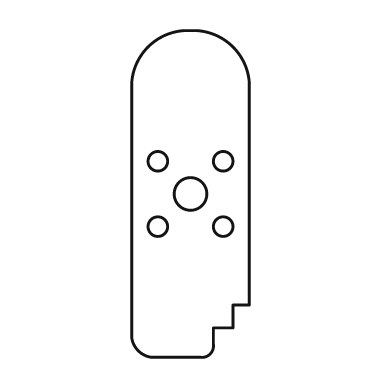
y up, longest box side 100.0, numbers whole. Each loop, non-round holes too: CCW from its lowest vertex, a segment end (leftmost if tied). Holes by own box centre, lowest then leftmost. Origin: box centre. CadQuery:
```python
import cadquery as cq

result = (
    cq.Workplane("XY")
    .moveTo(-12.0, -50.0)
    .lineTo(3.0, -50.0)
    .threePointArc((6.0, -49.0), (7.0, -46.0))
    .lineTo(7.0, -41.0)
    .lineTo(13.0, -41.0)
    .lineTo(13.0, -34.0)
    .lineTo(18.0, -34.0)
    .lineTo(18.0, 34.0)
    .threePointArc((13.0, 45.0), (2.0, 50.0))
    .lineTo(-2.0, 50.0)
    .threePointArc((-13.0, 45.0), (-18.0, 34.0))
    .lineTo(-18.0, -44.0)
    .threePointArc((-16.0, -48.0), (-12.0, -50.0))
    .close()
    .moveTo(-10.0, -10.0)
    .circle(3.0)
    .moveTo(10.0, -10.0)
    .circle(3.0)
    .moveTo(0.0, 0.0)
    .circle(5.0)
    .moveTo(-10.0, 10.0)
    .circle(3.0)
    .moveTo(10.0, 10.0)
    .circle(3.0)
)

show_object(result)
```